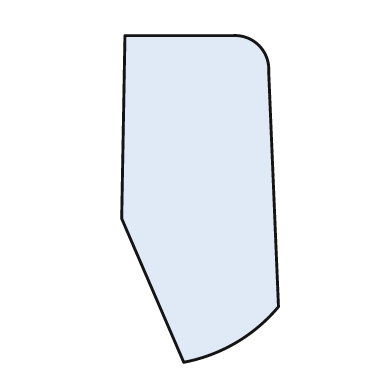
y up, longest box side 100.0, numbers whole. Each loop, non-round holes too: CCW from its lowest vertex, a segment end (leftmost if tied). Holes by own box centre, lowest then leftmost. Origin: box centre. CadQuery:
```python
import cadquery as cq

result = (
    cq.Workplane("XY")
    .moveTo(-5.0, -50.0)
    .threePointArc((11.0, -44.0), (24.0, -33.0))
    .lineTo(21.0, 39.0)
    .threePointArc((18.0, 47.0), (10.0, 50.0))
    .lineTo(-23.0, 50.0)
    .lineTo(-24.0, -6.0)
    .close()
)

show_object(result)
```